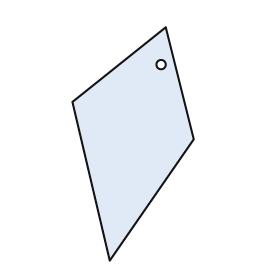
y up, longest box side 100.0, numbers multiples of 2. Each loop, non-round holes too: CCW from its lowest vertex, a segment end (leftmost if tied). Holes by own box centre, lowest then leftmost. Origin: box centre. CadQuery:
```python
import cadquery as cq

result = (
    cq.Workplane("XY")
    .moveTo(-10.0, -50.0)
    .lineTo(26.0, 2.0)
    .lineTo(14.0, 50.0)
    .lineTo(-26.0, 18.0)
    .close()
    .moveTo(12.0, 34.0)
    .circle(2.0)
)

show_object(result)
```